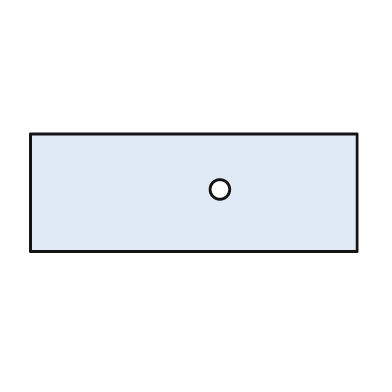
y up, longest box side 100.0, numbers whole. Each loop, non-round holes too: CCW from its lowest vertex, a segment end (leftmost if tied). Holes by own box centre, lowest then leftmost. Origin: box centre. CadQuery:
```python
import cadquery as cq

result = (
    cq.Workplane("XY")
    .moveTo(-50.0, -18.0)
    .lineTo(50.0, -18.0)
    .lineTo(50.0, 18.0)
    .lineTo(-50.0, 18.0)
    .close()
    .moveTo(8.0, 1.0)
    .circle(3.0)
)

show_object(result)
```